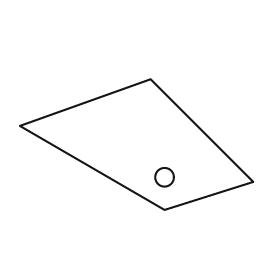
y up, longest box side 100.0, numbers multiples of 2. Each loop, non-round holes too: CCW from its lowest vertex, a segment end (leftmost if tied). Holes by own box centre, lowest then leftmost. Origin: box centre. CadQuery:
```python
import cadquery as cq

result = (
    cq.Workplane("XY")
    .moveTo(12.0, -28.0)
    .lineTo(50.0, -16.0)
    .lineTo(6.0, 28.0)
    .lineTo(-50.0, 8.0)
    .close()
    .moveTo(12.0, -14.0)
    .circle(4.0)
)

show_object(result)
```